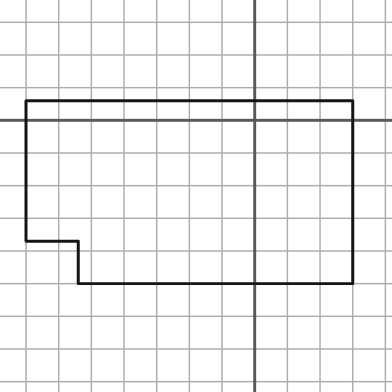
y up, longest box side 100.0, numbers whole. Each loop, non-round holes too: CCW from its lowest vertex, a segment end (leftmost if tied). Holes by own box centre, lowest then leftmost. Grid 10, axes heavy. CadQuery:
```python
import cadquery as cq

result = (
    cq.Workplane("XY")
    .moveTo(-54.0, -50.0)
    .lineTo(30.0, -50.0)
    .lineTo(30.0, 6.0)
    .lineTo(-70.0, 6.0)
    .lineTo(-70.0, -37.0)
    .lineTo(-54.0, -37.0)
    .close()
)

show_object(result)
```